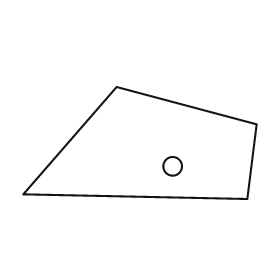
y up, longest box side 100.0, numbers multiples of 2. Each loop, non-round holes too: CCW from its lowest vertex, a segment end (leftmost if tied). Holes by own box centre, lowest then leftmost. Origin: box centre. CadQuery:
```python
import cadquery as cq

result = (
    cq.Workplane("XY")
    .moveTo(46.0, -24.0)
    .lineTo(50.0, 8.0)
    .lineTo(-10.0, 24.0)
    .lineTo(-50.0, -22.0)
    .close()
    .moveTo(14.0, -10.0)
    .circle(4.0)
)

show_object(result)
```